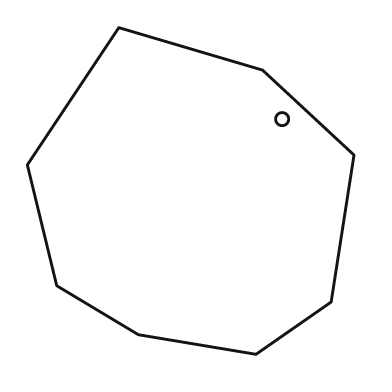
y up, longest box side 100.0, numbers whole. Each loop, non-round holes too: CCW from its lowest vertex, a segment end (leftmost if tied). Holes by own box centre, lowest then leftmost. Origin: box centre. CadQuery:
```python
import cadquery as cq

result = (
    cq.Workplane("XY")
    .moveTo(20.0, -50.0)
    .lineTo(43.0, -34.0)
    .lineTo(50.0, 11.0)
    .lineTo(22.0, 37.0)
    .lineTo(-22.0, 50.0)
    .lineTo(-50.0, 8.0)
    .lineTo(-41.0, -29.0)
    .lineTo(-16.0, -44.0)
    .close()
    .moveTo(28.0, 22.0)
    .circle(2.0)
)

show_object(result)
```